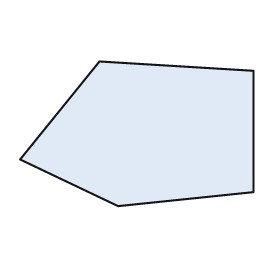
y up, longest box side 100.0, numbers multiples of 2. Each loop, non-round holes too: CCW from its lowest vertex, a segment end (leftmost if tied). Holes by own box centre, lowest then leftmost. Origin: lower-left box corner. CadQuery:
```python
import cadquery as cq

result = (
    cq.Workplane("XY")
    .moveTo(42.0, 0.0)
    .lineTo(100.0, 6.0)
    .lineTo(100.0, 58.0)
    .lineTo(34.0, 62.0)
    .lineTo(0.0, 20.0)
    .close()
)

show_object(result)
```